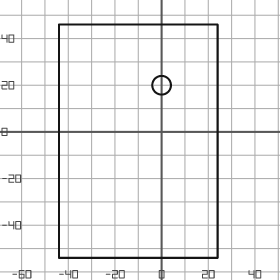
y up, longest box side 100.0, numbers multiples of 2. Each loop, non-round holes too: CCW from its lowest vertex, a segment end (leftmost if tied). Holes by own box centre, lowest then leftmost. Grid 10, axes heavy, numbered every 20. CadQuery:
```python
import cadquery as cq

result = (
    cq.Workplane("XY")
    .moveTo(-44.0, -54.0)
    .lineTo(24.0, -54.0)
    .lineTo(24.0, 46.0)
    .lineTo(-44.0, 46.0)
    .close()
    .moveTo(0.0, 20.0)
    .circle(4.0)
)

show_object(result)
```